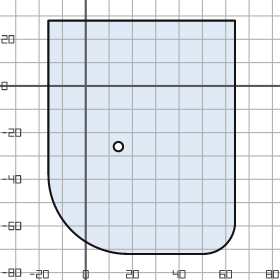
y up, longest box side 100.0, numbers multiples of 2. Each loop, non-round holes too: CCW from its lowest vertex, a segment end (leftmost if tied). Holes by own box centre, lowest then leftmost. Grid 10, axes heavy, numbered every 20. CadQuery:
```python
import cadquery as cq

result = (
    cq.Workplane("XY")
    .moveTo(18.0, -72.0)
    .lineTo(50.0, -72.0)
    .threePointArc((60.0, -68.0), (64.0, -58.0))
    .lineTo(64.0, 28.0)
    .lineTo(-16.0, 28.0)
    .lineTo(-16.0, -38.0)
    .threePointArc((-6.0, -62.0), (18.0, -72.0))
    .close()
    .moveTo(14.0, -26.0)
    .circle(2.0)
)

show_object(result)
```